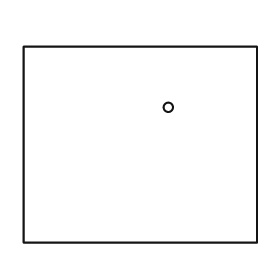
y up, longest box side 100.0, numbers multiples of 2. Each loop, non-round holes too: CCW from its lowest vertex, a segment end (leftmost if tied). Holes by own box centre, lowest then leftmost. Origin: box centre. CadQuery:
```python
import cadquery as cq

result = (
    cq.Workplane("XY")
    .moveTo(-50.0, -42.0)
    .lineTo(50.0, -42.0)
    .lineTo(50.0, 42.0)
    .lineTo(-50.0, 42.0)
    .close()
    .moveTo(12.0, 16.0)
    .circle(2.0)
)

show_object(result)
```